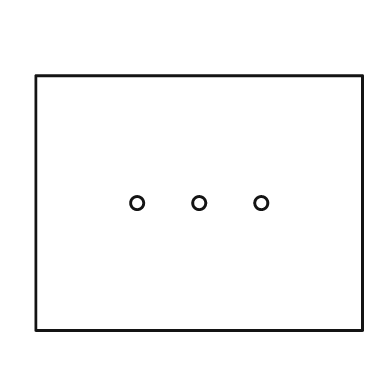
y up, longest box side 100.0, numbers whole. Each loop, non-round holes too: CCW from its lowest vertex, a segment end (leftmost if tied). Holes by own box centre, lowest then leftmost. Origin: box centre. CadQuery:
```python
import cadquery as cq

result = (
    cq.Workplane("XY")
    .moveTo(-50.0, -39.0)
    .lineTo(50.0, -39.0)
    .lineTo(50.0, 39.0)
    .lineTo(-50.0, 39.0)
    .close()
    .moveTo(-19.0, 0.0)
    .circle(2.0)
    .moveTo(0.0, 0.0)
    .circle(2.0)
    .moveTo(19.0, 0.0)
    .circle(2.0)
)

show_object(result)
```